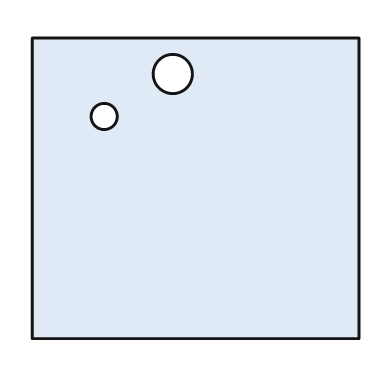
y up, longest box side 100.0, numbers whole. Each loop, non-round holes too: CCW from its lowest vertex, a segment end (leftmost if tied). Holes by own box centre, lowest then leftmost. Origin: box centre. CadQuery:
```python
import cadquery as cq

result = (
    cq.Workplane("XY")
    .moveTo(-50.0, -46.0)
    .lineTo(50.0, -46.0)
    .lineTo(50.0, 46.0)
    .lineTo(-50.0, 46.0)
    .close()
    .moveTo(-28.0, 22.0)
    .circle(4.0)
    .moveTo(-7.0, 35.0)
    .circle(6.0)
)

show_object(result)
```